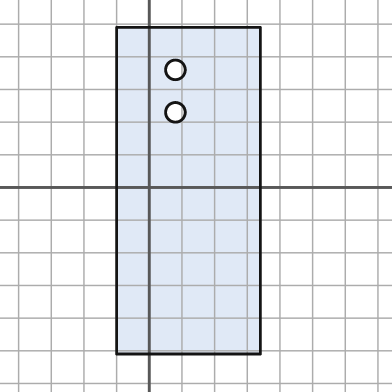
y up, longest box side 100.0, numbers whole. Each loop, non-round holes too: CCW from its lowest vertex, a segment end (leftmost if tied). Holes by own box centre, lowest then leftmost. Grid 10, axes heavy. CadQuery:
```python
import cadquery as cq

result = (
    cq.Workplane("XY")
    .moveTo(-10.0, -51.0)
    .lineTo(34.0, -51.0)
    .lineTo(34.0, 49.0)
    .lineTo(-10.0, 49.0)
    .close()
    .moveTo(8.0, 23.0)
    .circle(3.0)
    .moveTo(8.0, 36.0)
    .circle(3.0)
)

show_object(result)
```